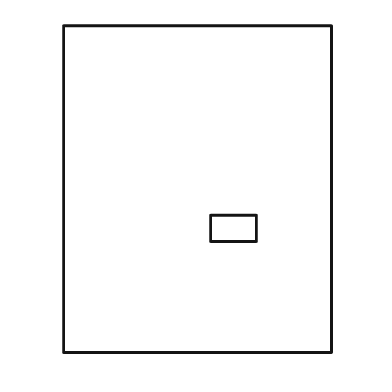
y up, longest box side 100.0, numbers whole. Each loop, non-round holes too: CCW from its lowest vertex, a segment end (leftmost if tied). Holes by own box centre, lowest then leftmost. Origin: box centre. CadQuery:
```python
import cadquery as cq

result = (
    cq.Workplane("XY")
    .moveTo(-41.0, -50.0)
    .lineTo(41.0, -50.0)
    .lineTo(41.0, 50.0)
    .lineTo(-41.0, 50.0)
    .close()
    .moveTo(4.0, -16.0)
    .lineTo(18.0, -16.0)
    .lineTo(18.0, -8.0)
    .lineTo(4.0, -8.0)
    .close()
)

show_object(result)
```